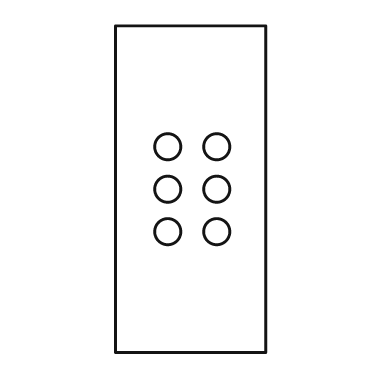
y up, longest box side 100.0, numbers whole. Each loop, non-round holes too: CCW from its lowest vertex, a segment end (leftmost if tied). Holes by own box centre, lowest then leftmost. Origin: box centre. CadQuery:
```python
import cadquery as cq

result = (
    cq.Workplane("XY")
    .moveTo(-23.0, -50.0)
    .lineTo(23.0, -50.0)
    .lineTo(23.0, 50.0)
    .lineTo(-23.0, 50.0)
    .close()
    .moveTo(-7.0, -13.0)
    .circle(4.0)
    .moveTo(8.0, -13.0)
    .circle(4.0)
    .moveTo(-7.0, 0.0)
    .circle(4.0)
    .moveTo(8.0, 0.0)
    .circle(4.0)
    .moveTo(-7.0, 13.0)
    .circle(4.0)
    .moveTo(8.0, 13.0)
    .circle(4.0)
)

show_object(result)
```